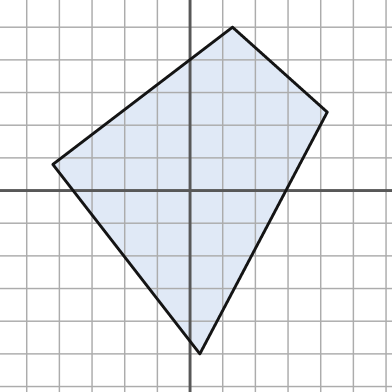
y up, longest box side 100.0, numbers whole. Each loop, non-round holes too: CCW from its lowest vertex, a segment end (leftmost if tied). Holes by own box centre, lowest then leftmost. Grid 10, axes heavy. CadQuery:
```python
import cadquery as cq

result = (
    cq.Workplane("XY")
    .moveTo(3.0, -50.0)
    .lineTo(42.0, 24.0)
    .lineTo(13.0, 50.0)
    .lineTo(-42.0, 8.0)
    .close()
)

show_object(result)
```